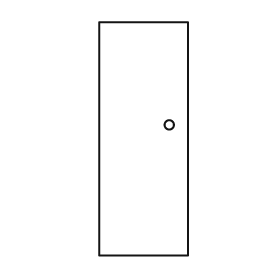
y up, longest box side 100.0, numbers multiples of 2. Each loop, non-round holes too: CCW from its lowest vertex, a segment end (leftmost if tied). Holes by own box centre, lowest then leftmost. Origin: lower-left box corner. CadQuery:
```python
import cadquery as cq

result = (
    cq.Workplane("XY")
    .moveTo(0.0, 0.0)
    .lineTo(38.0, 0.0)
    .lineTo(38.0, 100.0)
    .lineTo(0.0, 100.0)
    .close()
    .moveTo(30.0, 56.0)
    .circle(2.0)
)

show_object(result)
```